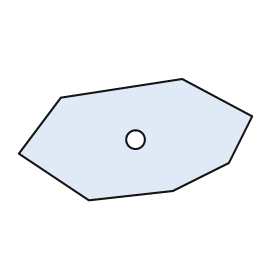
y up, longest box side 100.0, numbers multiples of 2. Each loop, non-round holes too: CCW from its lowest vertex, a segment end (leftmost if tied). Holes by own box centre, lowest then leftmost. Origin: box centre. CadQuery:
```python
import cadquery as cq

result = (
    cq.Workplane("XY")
    .moveTo(-20.0, -26.0)
    .lineTo(16.0, -22.0)
    .lineTo(40.0, -10.0)
    .lineTo(50.0, 10.0)
    .lineTo(20.0, 26.0)
    .lineTo(-32.0, 18.0)
    .lineTo(-50.0, -6.0)
    .close()
    .moveTo(0.0, 0.0)
    .circle(4.0)
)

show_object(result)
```